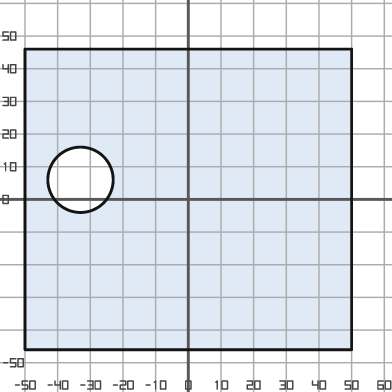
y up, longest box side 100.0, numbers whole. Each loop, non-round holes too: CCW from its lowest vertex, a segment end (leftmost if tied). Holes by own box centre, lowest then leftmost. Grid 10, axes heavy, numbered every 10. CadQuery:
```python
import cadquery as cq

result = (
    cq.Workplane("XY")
    .moveTo(-50.0, -46.0)
    .lineTo(50.0, -46.0)
    .lineTo(50.0, 46.0)
    .lineTo(-50.0, 46.0)
    .close()
    .moveTo(-33.0, 6.0)
    .circle(10.0)
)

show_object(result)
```